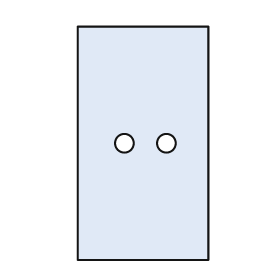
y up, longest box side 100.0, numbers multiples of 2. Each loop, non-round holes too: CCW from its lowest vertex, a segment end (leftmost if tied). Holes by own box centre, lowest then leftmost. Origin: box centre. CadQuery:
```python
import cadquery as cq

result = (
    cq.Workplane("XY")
    .moveTo(-28.0, -50.0)
    .lineTo(28.0, -50.0)
    .lineTo(28.0, 50.0)
    .lineTo(-28.0, 50.0)
    .close()
    .moveTo(-8.0, 0.0)
    .circle(4.0)
    .moveTo(10.0, 0.0)
    .circle(4.0)
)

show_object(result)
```